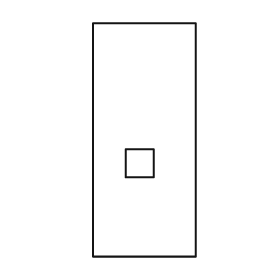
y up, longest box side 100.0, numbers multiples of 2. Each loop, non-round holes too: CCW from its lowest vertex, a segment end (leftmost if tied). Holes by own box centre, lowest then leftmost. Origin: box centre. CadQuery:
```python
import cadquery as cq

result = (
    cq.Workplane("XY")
    .moveTo(-22.0, -50.0)
    .lineTo(22.0, -50.0)
    .lineTo(22.0, 50.0)
    .lineTo(-22.0, 50.0)
    .close()
    .moveTo(-8.0, -16.0)
    .lineTo(4.0, -16.0)
    .lineTo(4.0, -4.0)
    .lineTo(-8.0, -4.0)
    .close()
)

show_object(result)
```